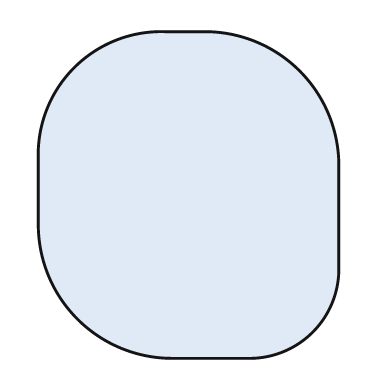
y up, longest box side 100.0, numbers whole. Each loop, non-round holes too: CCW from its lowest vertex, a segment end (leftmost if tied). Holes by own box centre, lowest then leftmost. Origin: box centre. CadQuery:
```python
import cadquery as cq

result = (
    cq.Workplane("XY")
    .moveTo(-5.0, -50.0)
    .lineTo(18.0, -50.0)
    .threePointArc((38.0, -42.0), (46.0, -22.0))
    .lineTo(46.0, 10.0)
    .threePointArc((34.0, 38.0), (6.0, 50.0))
    .lineTo(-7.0, 50.0)
    .threePointArc((-35.0, 39.0), (-46.0, 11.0))
    .lineTo(-46.0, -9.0)
    .threePointArc((-34.0, -38.0), (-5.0, -50.0))
    .close()
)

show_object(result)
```